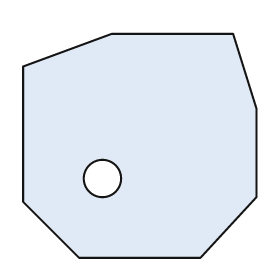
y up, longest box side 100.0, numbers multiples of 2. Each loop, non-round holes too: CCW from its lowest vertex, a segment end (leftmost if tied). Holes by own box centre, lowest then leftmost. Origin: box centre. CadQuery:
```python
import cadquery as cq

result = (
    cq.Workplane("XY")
    .moveTo(-26.0, -48.0)
    .lineTo(26.0, -48.0)
    .lineTo(50.0, -22.0)
    .lineTo(50.0, 16.0)
    .lineTo(40.0, 48.0)
    .lineTo(-12.0, 48.0)
    .lineTo(-50.0, 34.0)
    .lineTo(-50.0, -24.0)
    .close()
    .moveTo(-16.0, -14.0)
    .circle(8.0)
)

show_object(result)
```